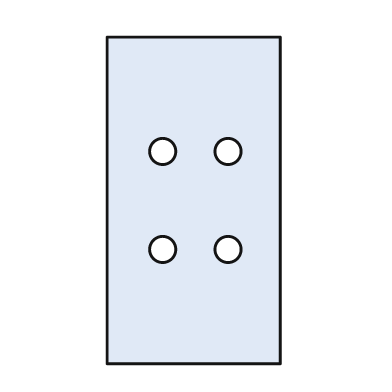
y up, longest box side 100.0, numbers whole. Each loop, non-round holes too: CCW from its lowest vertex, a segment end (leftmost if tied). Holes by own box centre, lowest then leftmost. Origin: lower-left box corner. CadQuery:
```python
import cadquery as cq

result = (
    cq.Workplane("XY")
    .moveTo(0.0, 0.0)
    .lineTo(53.0, 0.0)
    .lineTo(53.0, 100.0)
    .lineTo(0.0, 100.0)
    .close()
    .moveTo(17.0, 35.0)
    .circle(4.0)
    .moveTo(37.0, 35.0)
    .circle(4.0)
    .moveTo(17.0, 65.0)
    .circle(4.0)
    .moveTo(37.0, 65.0)
    .circle(4.0)
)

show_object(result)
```